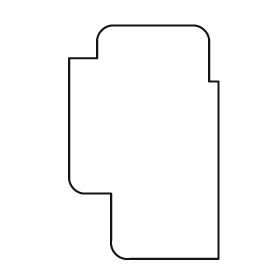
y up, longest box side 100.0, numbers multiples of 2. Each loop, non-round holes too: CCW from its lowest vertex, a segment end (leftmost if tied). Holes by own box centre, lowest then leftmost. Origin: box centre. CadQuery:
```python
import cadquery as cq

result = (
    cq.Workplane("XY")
    .moveTo(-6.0, -50.0)
    .lineTo(32.0, -50.0)
    .lineTo(32.0, 26.0)
    .lineTo(28.0, 26.0)
    .lineTo(28.0, 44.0)
    .threePointArc((26.0, 48.0), (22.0, 50.0))
    .lineTo(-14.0, 50.0)
    .threePointArc((-18.0, 48.0), (-20.0, 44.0))
    .lineTo(-20.0, 36.0)
    .lineTo(-32.0, 36.0)
    .lineTo(-32.0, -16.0)
    .threePointArc((-30.0, -20.0), (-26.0, -22.0))
    .lineTo(-14.0, -22.0)
    .lineTo(-14.0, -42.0)
    .threePointArc((-12.0, -48.0), (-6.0, -50.0))
    .close()
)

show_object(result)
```